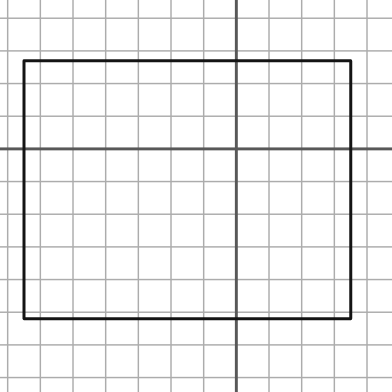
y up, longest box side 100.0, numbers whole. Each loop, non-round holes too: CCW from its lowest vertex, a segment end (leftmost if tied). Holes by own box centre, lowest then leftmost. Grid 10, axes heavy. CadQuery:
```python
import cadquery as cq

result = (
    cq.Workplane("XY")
    .moveTo(-65.0, -52.0)
    .lineTo(35.0, -52.0)
    .lineTo(35.0, 27.0)
    .lineTo(-65.0, 27.0)
    .close()
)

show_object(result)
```